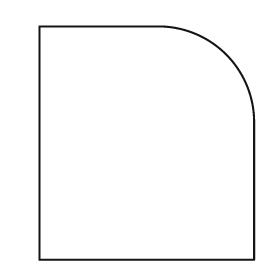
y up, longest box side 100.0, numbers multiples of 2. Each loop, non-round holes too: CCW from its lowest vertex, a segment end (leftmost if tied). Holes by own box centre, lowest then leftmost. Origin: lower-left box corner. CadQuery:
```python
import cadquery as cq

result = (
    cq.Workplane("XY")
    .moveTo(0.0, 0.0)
    .lineTo(92.0, 0.0)
    .lineTo(92.0, 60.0)
    .threePointArc((80.0, 88.0), (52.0, 100.0))
    .lineTo(0.0, 100.0)
    .close()
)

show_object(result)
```